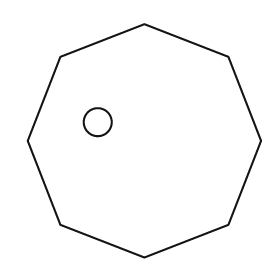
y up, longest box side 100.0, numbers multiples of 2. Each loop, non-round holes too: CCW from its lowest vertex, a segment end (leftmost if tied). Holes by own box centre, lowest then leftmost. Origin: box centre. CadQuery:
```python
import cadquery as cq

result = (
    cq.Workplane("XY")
    .moveTo(0.0, -50.0)
    .lineTo(36.0, -36.0)
    .lineTo(50.0, 0.0)
    .lineTo(36.0, 36.0)
    .lineTo(0.0, 50.0)
    .lineTo(-36.0, 36.0)
    .lineTo(-50.0, 0.0)
    .lineTo(-36.0, -36.0)
    .close()
    .moveTo(-20.0, 8.0)
    .circle(6.0)
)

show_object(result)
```